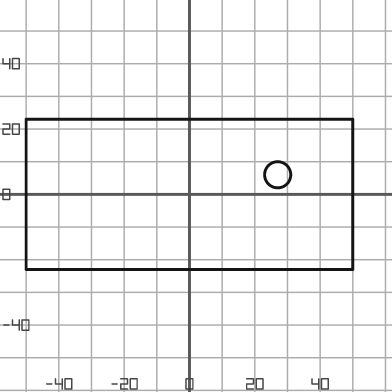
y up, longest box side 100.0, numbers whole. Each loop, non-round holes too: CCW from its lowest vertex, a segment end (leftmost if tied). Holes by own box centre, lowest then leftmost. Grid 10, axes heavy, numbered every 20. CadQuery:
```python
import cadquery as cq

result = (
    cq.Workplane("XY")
    .moveTo(-50.0, -23.0)
    .lineTo(50.0, -23.0)
    .lineTo(50.0, 23.0)
    .lineTo(-50.0, 23.0)
    .close()
    .moveTo(27.0, 6.0)
    .circle(4.0)
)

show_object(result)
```